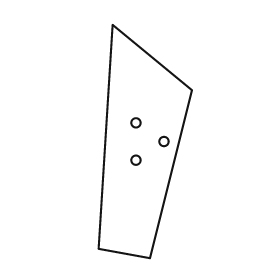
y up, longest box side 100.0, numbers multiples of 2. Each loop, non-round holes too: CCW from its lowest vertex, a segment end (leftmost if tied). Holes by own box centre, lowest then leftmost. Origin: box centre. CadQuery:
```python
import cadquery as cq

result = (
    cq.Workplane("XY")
    .moveTo(2.0, -50.0)
    .lineTo(20.0, 22.0)
    .lineTo(-14.0, 50.0)
    .lineTo(-20.0, -46.0)
    .close()
    .moveTo(-4.0, -8.0)
    .circle(2.0)
    .moveTo(8.0, 0.0)
    .circle(2.0)
    .moveTo(-4.0, 8.0)
    .circle(2.0)
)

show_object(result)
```